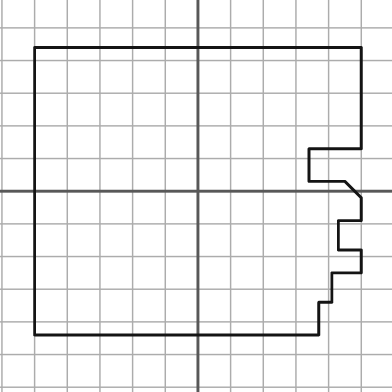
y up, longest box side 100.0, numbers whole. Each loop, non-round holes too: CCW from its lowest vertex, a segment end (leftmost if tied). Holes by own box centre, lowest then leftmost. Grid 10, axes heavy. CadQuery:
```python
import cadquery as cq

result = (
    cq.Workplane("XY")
    .moveTo(-50.0, -44.0)
    .lineTo(37.0, -44.0)
    .lineTo(37.0, -34.0)
    .lineTo(41.0, -34.0)
    .lineTo(41.0, -25.0)
    .lineTo(50.0, -25.0)
    .lineTo(50.0, -18.0)
    .lineTo(43.0, -18.0)
    .lineTo(43.0, -9.0)
    .lineTo(50.0, -9.0)
    .lineTo(50.0, -2.0)
    .lineTo(45.0, 3.0)
    .lineTo(34.0, 3.0)
    .lineTo(34.0, 13.0)
    .lineTo(50.0, 13.0)
    .lineTo(50.0, 44.0)
    .lineTo(-50.0, 44.0)
    .close()
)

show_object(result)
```